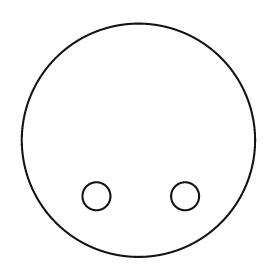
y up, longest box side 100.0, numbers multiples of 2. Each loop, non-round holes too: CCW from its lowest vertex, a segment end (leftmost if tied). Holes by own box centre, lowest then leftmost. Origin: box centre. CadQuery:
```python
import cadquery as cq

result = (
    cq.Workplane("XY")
    .moveTo(0.0, 0.0)
    .circle(50.0)
    .moveTo(-18.0, -24.0)
    .circle(6.0)
    .moveTo(20.0, -24.0)
    .circle(6.0)
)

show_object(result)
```